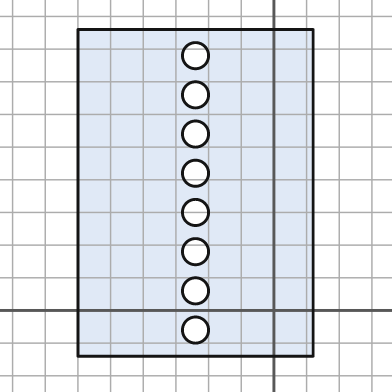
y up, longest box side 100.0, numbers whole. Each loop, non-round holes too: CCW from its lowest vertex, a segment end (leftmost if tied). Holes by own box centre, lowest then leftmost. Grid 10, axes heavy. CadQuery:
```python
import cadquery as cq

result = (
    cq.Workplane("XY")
    .moveTo(-60.0, -14.0)
    .lineTo(12.0, -14.0)
    .lineTo(12.0, 86.0)
    .lineTo(-60.0, 86.0)
    .close()
    .moveTo(-24.0, -6.0)
    .circle(4.0)
    .moveTo(-24.0, 6.0)
    .circle(4.0)
    .moveTo(-24.0, 18.0)
    .circle(4.0)
    .moveTo(-24.0, 30.0)
    .circle(4.0)
    .moveTo(-24.0, 42.0)
    .circle(4.0)
    .moveTo(-24.0, 54.0)
    .circle(4.0)
    .moveTo(-24.0, 66.0)
    .circle(4.0)
    .moveTo(-24.0, 78.0)
    .circle(4.0)
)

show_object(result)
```